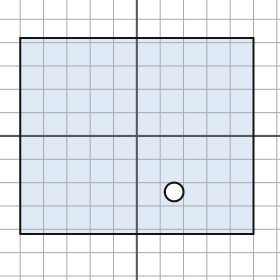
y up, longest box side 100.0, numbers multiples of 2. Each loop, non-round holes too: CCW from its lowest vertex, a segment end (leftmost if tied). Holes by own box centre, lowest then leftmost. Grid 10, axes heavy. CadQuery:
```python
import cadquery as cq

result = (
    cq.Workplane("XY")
    .moveTo(-50.0, -42.0)
    .lineTo(50.0, -42.0)
    .lineTo(50.0, 42.0)
    .lineTo(-50.0, 42.0)
    .close()
    .moveTo(16.0, -24.0)
    .circle(4.0)
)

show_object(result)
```